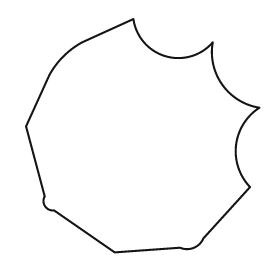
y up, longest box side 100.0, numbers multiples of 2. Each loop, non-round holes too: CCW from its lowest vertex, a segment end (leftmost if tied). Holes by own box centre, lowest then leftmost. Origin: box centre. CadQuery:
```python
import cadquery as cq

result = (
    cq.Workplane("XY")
    .moveTo(-12.0, -50.0)
    .lineTo(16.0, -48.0)
    .threePointArc((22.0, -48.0), (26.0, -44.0))
    .lineTo(46.0, -22.0)
    .threePointArc((40.0, -4.0), (50.0, 12.0))
    .threePointArc((34.0, 22.0), (30.0, 40.0))
    .threePointArc((10.0, 34.0), (-4.0, 50.0))
    .lineTo(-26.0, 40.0)
    .threePointArc((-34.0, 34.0), (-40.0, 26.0))
    .lineTo(-50.0, 4.0)
    .lineTo(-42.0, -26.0)
    .threePointArc((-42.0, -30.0), (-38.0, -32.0))
    .close()
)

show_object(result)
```